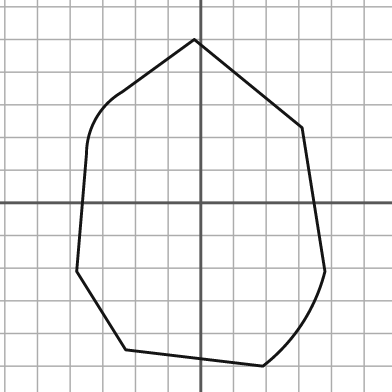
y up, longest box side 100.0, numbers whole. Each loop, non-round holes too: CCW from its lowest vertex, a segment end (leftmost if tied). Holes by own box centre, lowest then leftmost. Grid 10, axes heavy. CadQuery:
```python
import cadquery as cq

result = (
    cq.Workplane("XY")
    .moveTo(19.0, -50.0)
    .threePointArc((31.0, -37.0), (38.0, -21.0))
    .lineTo(31.0, 23.0)
    .lineTo(-2.0, 50.0)
    .lineTo(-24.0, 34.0)
    .threePointArc((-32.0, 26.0), (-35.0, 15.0))
    .lineTo(-38.0, -21.0)
    .lineTo(-23.0, -45.0)
    .close()
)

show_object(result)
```